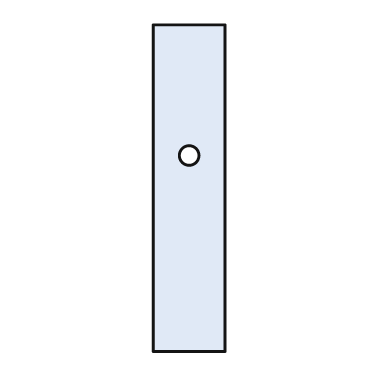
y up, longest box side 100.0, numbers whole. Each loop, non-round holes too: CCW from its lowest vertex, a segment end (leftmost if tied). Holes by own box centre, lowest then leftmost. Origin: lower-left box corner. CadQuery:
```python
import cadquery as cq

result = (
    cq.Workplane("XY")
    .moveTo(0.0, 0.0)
    .lineTo(22.0, 0.0)
    .lineTo(22.0, 100.0)
    .lineTo(0.0, 100.0)
    .close()
    .moveTo(11.0, 60.0)
    .circle(3.0)
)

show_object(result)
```